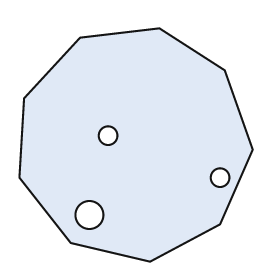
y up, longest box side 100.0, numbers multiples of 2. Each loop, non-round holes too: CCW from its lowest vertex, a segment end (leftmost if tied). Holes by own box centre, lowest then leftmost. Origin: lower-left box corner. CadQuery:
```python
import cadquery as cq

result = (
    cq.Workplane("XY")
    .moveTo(56.0, 0.0)
    .lineTo(86.0, 16.0)
    .lineTo(100.0, 48.0)
    .lineTo(88.0, 82.0)
    .lineTo(60.0, 100.0)
    .lineTo(26.0, 96.0)
    .lineTo(2.0, 70.0)
    .lineTo(0.0, 36.0)
    .lineTo(22.0, 8.0)
    .close()
    .moveTo(30.0, 20.0)
    .circle(6.0)
    .moveTo(86.0, 36.0)
    .circle(4.0)
    .moveTo(38.0, 54.0)
    .circle(4.0)
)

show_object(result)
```